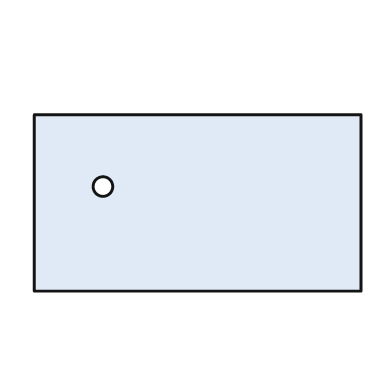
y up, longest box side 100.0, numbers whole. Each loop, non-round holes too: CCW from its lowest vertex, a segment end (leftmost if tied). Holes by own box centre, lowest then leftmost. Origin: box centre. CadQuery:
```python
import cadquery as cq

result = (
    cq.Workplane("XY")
    .moveTo(-50.0, -27.0)
    .lineTo(50.0, -27.0)
    .lineTo(50.0, 27.0)
    .lineTo(-50.0, 27.0)
    .close()
    .moveTo(-29.0, 5.0)
    .circle(3.0)
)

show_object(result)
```